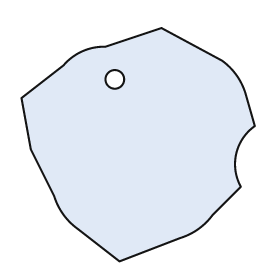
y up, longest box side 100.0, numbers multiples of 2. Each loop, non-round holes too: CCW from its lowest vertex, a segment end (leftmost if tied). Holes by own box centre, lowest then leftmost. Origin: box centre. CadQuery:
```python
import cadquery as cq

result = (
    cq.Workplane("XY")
    .moveTo(-8.0, -50.0)
    .lineTo(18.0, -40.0)
    .threePointArc((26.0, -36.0), (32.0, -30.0))
    .lineTo(44.0, -18.0)
    .threePointArc((42.0, -4.0), (50.0, 8.0))
    .lineTo(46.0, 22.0)
    .threePointArc((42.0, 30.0), (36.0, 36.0))
    .lineTo(10.0, 50.0)
    .lineTo(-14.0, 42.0)
    .threePointArc((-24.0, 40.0), (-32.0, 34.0))
    .lineTo(-50.0, 20.0)
    .lineTo(-46.0, -2.0)
    .lineTo(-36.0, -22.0)
    .threePointArc((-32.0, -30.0), (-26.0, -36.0))
    .close()
    .moveTo(-10.0, 28.0)
    .circle(4.0)
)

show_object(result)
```